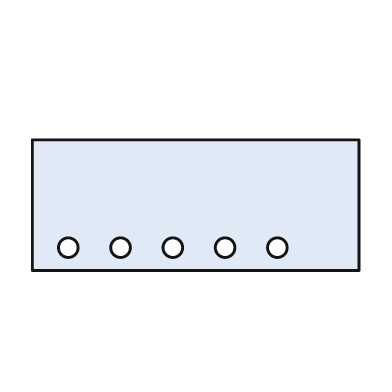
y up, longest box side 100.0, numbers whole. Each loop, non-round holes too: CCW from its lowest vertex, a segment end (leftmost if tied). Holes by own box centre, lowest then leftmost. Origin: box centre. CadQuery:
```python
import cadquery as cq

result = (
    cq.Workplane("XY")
    .moveTo(-50.0, -20.0)
    .lineTo(50.0, -20.0)
    .lineTo(50.0, 20.0)
    .lineTo(-50.0, 20.0)
    .close()
    .moveTo(-39.0, -13.0)
    .circle(3.0)
    .moveTo(-23.0, -13.0)
    .circle(3.0)
    .moveTo(-7.0, -13.0)
    .circle(3.0)
    .moveTo(9.0, -13.0)
    .circle(3.0)
    .moveTo(25.0, -13.0)
    .circle(3.0)
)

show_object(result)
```